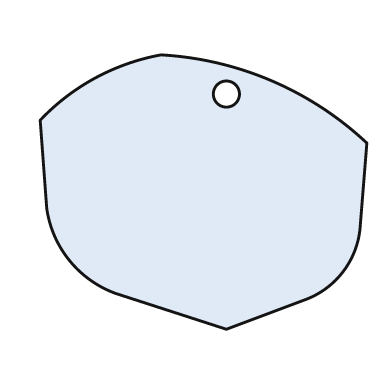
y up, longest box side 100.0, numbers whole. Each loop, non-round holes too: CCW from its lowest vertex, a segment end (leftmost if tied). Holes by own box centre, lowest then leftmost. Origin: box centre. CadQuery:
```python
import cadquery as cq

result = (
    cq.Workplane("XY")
    .moveTo(7.0, -42.0)
    .lineTo(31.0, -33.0)
    .threePointArc((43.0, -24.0), (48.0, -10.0))
    .lineTo(50.0, 15.0)
    .threePointArc((21.0, 34.0), (-13.0, 42.0))
    .threePointArc((-33.0, 35.0), (-50.0, 22.0))
    .lineTo(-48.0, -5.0)
    .threePointArc((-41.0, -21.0), (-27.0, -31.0))
    .close()
    .moveTo(7.0, 30.0)
    .circle(4.0)
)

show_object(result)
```